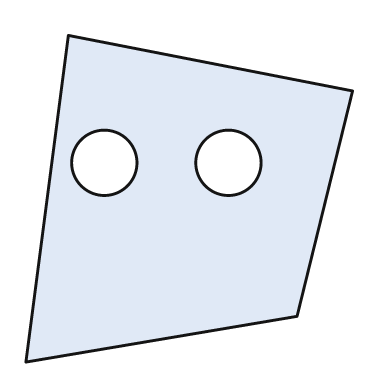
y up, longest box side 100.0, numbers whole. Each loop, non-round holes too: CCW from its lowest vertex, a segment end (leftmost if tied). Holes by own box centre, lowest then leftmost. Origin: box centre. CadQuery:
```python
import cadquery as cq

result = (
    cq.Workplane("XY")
    .moveTo(-50.0, -50.0)
    .lineTo(33.0, -36.0)
    .lineTo(50.0, 33.0)
    .lineTo(-37.0, 50.0)
    .close()
    .moveTo(-26.0, 11.0)
    .circle(10.0)
    .moveTo(12.0, 11.0)
    .circle(10.0)
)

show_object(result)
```